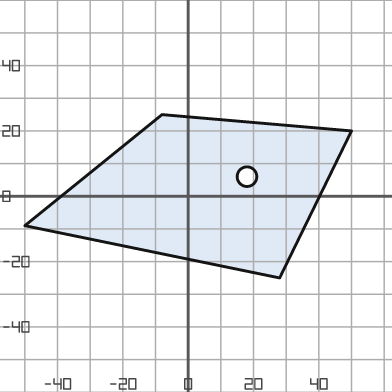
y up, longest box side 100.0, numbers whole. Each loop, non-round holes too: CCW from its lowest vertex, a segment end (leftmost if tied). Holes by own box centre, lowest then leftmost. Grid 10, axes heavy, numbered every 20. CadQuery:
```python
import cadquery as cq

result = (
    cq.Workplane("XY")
    .moveTo(28.0, -25.0)
    .lineTo(50.0, 20.0)
    .lineTo(-8.0, 25.0)
    .lineTo(-50.0, -9.0)
    .close()
    .moveTo(18.0, 6.0)
    .circle(3.0)
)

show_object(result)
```